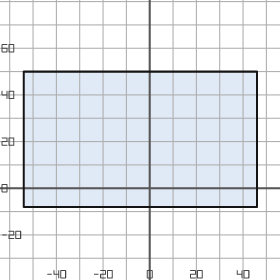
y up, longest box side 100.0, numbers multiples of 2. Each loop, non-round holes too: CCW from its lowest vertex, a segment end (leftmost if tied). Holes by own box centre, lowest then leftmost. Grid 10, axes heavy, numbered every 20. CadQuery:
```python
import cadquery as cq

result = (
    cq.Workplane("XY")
    .moveTo(-54.0, -8.0)
    .lineTo(46.0, -8.0)
    .lineTo(46.0, 50.0)
    .lineTo(-54.0, 50.0)
    .close()
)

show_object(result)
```